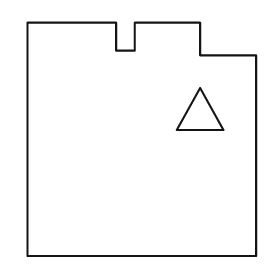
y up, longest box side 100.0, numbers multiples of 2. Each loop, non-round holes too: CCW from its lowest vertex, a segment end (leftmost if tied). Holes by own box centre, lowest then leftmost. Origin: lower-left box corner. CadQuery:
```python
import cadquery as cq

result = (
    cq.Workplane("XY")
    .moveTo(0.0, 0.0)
    .lineTo(98.0, 0.0)
    .lineTo(98.0, 86.0)
    .lineTo(74.0, 86.0)
    .lineTo(74.0, 100.0)
    .lineTo(46.0, 100.0)
    .lineTo(46.0, 88.0)
    .lineTo(38.0, 88.0)
    .lineTo(38.0, 100.0)
    .lineTo(0.0, 100.0)
    .close()
    .moveTo(64.0, 54.0)
    .lineTo(84.0, 54.0)
    .lineTo(74.0, 72.0)
    .close()
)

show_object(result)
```